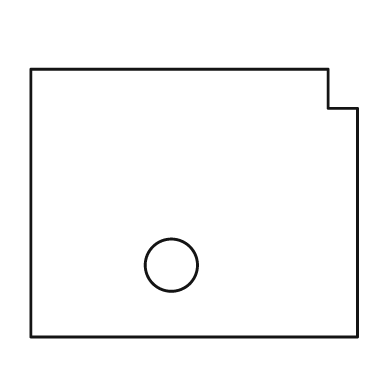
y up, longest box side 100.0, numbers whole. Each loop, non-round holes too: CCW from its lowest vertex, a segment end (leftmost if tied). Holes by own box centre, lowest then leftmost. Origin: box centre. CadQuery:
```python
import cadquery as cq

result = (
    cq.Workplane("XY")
    .moveTo(-50.0, -41.0)
    .lineTo(50.0, -41.0)
    .lineTo(50.0, 29.0)
    .lineTo(41.0, 29.0)
    .lineTo(41.0, 41.0)
    .lineTo(-50.0, 41.0)
    .close()
    .moveTo(-7.0, -19.0)
    .circle(8.0)
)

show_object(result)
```